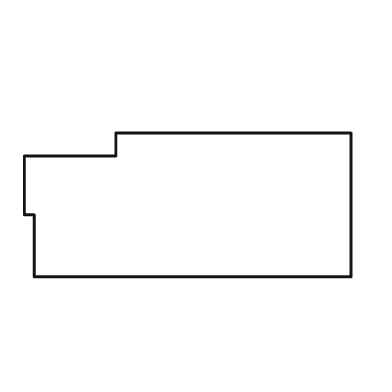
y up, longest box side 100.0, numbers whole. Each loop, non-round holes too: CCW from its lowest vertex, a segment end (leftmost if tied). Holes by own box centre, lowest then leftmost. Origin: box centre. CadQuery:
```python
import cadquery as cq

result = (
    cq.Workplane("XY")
    .moveTo(-47.0, -22.0)
    .lineTo(50.0, -22.0)
    .lineTo(50.0, 22.0)
    .lineTo(-22.0, 22.0)
    .lineTo(-22.0, 15.0)
    .lineTo(-50.0, 15.0)
    .lineTo(-50.0, -3.0)
    .lineTo(-47.0, -3.0)
    .close()
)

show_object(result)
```